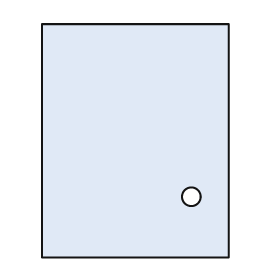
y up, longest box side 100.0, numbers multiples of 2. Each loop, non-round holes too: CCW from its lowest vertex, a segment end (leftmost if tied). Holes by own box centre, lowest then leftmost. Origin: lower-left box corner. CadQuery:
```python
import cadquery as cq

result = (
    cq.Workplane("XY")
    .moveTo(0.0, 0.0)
    .lineTo(80.0, 0.0)
    .lineTo(80.0, 100.0)
    .lineTo(0.0, 100.0)
    .close()
    .moveTo(64.0, 26.0)
    .circle(4.0)
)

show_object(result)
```